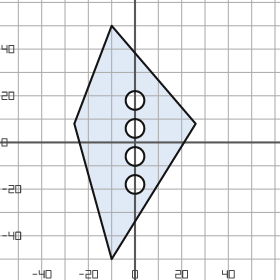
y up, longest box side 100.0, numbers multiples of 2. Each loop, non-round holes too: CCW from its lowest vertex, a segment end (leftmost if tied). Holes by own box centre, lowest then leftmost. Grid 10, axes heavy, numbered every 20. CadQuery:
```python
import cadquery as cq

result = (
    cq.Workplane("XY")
    .moveTo(-10.0, -50.0)
    .lineTo(26.0, 8.0)
    .lineTo(-10.0, 50.0)
    .lineTo(-26.0, 8.0)
    .close()
    .moveTo(0.0, -18.0)
    .circle(4.0)
    .moveTo(0.0, -6.0)
    .circle(4.0)
    .moveTo(0.0, 6.0)
    .circle(4.0)
    .moveTo(0.0, 18.0)
    .circle(4.0)
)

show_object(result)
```